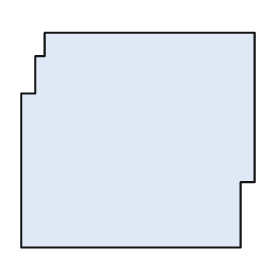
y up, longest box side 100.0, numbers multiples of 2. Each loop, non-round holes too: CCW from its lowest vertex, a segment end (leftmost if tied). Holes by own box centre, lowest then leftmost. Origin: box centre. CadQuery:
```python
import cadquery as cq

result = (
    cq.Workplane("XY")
    .moveTo(-50.0, -46.0)
    .lineTo(44.0, -46.0)
    .lineTo(44.0, -18.0)
    .lineTo(50.0, -18.0)
    .lineTo(50.0, 46.0)
    .lineTo(-40.0, 46.0)
    .lineTo(-40.0, 36.0)
    .lineTo(-44.0, 36.0)
    .lineTo(-44.0, 20.0)
    .lineTo(-50.0, 20.0)
    .close()
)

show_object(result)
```